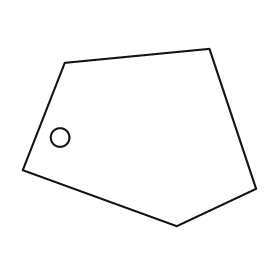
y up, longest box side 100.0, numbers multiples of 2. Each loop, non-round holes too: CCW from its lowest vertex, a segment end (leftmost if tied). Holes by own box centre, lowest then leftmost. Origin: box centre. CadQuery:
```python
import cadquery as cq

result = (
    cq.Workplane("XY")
    .moveTo(16.0, -38.0)
    .lineTo(50.0, -22.0)
    .lineTo(30.0, 38.0)
    .lineTo(-32.0, 32.0)
    .lineTo(-50.0, -14.0)
    .close()
    .moveTo(-34.0, 0.0)
    .circle(4.0)
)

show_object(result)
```